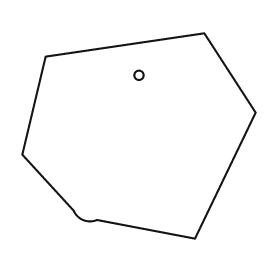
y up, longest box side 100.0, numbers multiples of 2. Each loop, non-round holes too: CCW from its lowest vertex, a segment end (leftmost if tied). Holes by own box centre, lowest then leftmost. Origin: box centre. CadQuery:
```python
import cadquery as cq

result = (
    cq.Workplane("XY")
    .moveTo(24.0, -44.0)
    .lineTo(50.0, 10.0)
    .lineTo(28.0, 44.0)
    .lineTo(-40.0, 34.0)
    .lineTo(-50.0, -8.0)
    .lineTo(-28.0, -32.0)
    .threePointArc((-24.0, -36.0), (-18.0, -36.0))
    .close()
    .moveTo(0.0, 26.0)
    .circle(2.0)
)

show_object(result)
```